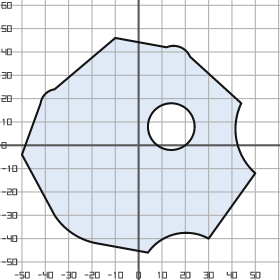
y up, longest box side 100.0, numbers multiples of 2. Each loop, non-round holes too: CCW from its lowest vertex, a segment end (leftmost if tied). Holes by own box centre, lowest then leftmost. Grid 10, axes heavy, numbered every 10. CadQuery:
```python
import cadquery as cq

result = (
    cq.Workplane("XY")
    .moveTo(4.0, -46.0)
    .threePointArc((16.0, -38.0), (30.0, -40.0))
    .lineTo(50.0, -12.0)
    .threePointArc((42.0, 2.0), (44.0, 18.0))
    .lineTo(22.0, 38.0)
    .threePointArc((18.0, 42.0), (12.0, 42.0))
    .lineTo(-10.0, 46.0)
    .lineTo(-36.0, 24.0)
    .threePointArc((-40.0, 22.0), (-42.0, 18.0))
    .lineTo(-50.0, -4.0)
    .lineTo(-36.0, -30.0)
    .threePointArc((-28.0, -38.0), (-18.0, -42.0))
    .close()
    .moveTo(14.0, 8.0)
    .circle(10.0)
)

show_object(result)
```